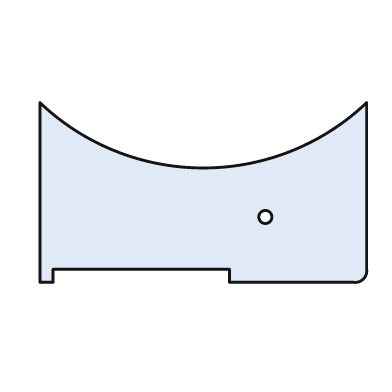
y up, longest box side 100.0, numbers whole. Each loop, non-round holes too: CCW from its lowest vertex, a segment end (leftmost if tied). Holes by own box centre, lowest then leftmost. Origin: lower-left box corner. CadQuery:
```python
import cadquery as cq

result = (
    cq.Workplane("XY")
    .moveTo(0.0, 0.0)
    .lineTo(4.0, 0.0)
    .lineTo(4.0, 4.0)
    .lineTo(58.0, 4.0)
    .lineTo(58.0, 0.0)
    .lineTo(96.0, 0.0)
    .threePointArc((99.0, 1.0), (100.0, 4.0))
    .lineTo(100.0, 55.0)
    .threePointArc((50.0, 35.0), (0.0, 55.0))
    .close()
    .moveTo(69.0, 20.0)
    .circle(2.0)
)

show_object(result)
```